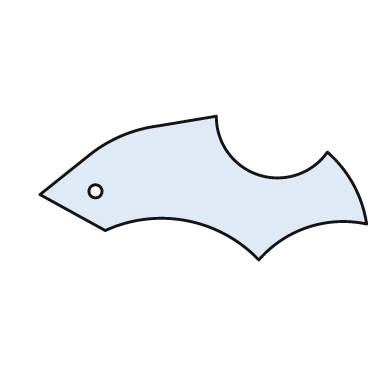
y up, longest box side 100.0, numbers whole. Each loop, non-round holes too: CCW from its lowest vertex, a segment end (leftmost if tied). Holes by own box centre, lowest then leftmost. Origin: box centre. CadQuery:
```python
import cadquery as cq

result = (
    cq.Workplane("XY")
    .moveTo(17.0, -22.0)
    .threePointArc((32.0, -12.0), (50.0, -11.0))
    .threePointArc((46.0, 1.0), (38.0, 11.0))
    .threePointArc((17.0, 4.0), (4.0, 22.0))
    .lineTo(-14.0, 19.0)
    .threePointArc((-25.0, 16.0), (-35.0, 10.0))
    .lineTo(-50.0, -2.0)
    .lineTo(-30.0, -13.0)
    .threePointArc((-5.0, -10.0), (17.0, -22.0))
    .close()
    .moveTo(-33.0, -1.0)
    .circle(2.0)
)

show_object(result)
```